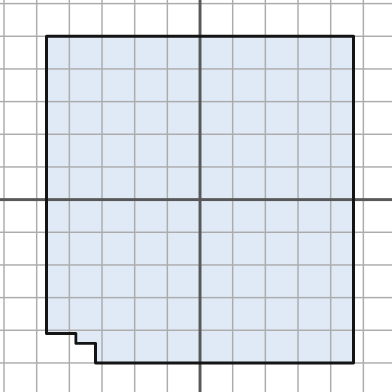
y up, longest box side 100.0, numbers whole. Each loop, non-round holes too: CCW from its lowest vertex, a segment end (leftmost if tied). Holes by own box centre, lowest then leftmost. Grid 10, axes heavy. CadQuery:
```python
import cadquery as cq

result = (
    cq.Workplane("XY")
    .moveTo(-32.0, -50.0)
    .lineTo(47.0, -50.0)
    .lineTo(47.0, 50.0)
    .lineTo(-47.0, 50.0)
    .lineTo(-47.0, -41.0)
    .lineTo(-38.0, -41.0)
    .lineTo(-38.0, -44.0)
    .lineTo(-32.0, -44.0)
    .close()
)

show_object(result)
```